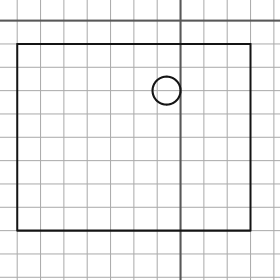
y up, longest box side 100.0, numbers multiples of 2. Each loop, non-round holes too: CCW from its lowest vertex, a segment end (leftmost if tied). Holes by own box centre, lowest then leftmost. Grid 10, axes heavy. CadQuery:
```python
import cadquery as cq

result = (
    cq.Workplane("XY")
    .moveTo(-70.0, -90.0)
    .lineTo(30.0, -90.0)
    .lineTo(30.0, -10.0)
    .lineTo(-70.0, -10.0)
    .close()
    .moveTo(-6.0, -30.0)
    .circle(6.0)
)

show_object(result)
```